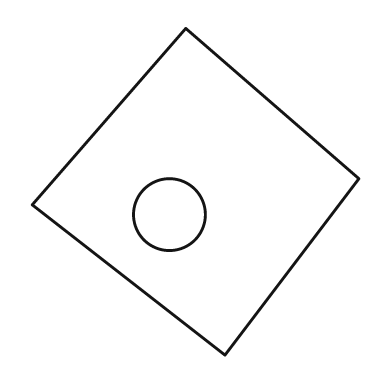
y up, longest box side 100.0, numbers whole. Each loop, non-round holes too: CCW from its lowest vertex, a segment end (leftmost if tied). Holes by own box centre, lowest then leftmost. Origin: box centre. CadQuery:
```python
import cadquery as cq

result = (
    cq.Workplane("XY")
    .moveTo(9.0, -50.0)
    .lineTo(50.0, 4.0)
    .lineTo(-3.0, 50.0)
    .lineTo(-50.0, -4.0)
    .close()
    .moveTo(-8.0, -7.0)
    .circle(11.0)
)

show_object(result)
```